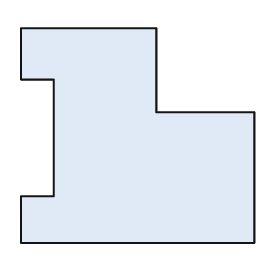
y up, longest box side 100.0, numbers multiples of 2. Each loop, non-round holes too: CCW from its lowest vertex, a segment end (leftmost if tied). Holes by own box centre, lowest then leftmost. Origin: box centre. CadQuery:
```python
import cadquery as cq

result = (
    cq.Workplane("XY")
    .moveTo(-50.0, -46.0)
    .lineTo(50.0, -46.0)
    .lineTo(50.0, 10.0)
    .lineTo(8.0, 10.0)
    .lineTo(8.0, 46.0)
    .lineTo(-50.0, 46.0)
    .lineTo(-50.0, 24.0)
    .lineTo(-36.0, 24.0)
    .lineTo(-36.0, -26.0)
    .lineTo(-50.0, -26.0)
    .close()
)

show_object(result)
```